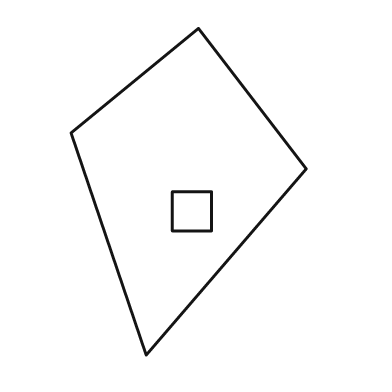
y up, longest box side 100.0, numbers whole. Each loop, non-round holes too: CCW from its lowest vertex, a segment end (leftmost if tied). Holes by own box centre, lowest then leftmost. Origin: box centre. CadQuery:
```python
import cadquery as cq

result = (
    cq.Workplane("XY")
    .moveTo(-13.0, -50.0)
    .lineTo(36.0, 7.0)
    .lineTo(3.0, 50.0)
    .lineTo(-36.0, 18.0)
    .close()
    .moveTo(-5.0, -12.0)
    .lineTo(7.0, -12.0)
    .lineTo(7.0, 0.0)
    .lineTo(-5.0, 0.0)
    .close()
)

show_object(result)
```